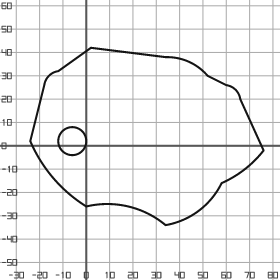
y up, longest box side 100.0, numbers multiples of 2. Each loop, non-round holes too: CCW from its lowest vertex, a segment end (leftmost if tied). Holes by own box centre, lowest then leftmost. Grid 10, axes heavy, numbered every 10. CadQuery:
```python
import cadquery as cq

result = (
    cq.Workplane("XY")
    .moveTo(34.0, -34.0)
    .threePointArc((48.0, -28.0), (58.0, -16.0))
    .threePointArc((68.0, -10.0), (76.0, -2.0))
    .lineTo(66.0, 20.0)
    .threePointArc((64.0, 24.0), (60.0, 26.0))
    .lineTo(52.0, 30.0)
    .threePointArc((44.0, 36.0), (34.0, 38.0))
    .lineTo(2.0, 42.0)
    .lineTo(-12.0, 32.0)
    .threePointArc((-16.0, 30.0), (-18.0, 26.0))
    .lineTo(-24.0, 2.0)
    .threePointArc((-14.0, -14.0), (0.0, -26.0))
    .threePointArc((18.0, -26.0), (34.0, -34.0))
    .close()
    .moveTo(-6.0, 2.0)
    .circle(6.0)
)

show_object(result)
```